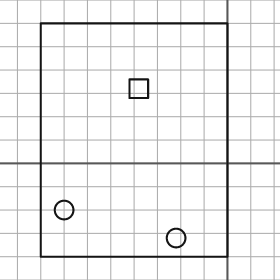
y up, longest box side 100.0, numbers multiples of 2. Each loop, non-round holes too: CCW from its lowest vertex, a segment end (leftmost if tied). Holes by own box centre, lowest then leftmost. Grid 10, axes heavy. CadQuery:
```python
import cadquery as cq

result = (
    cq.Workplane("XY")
    .moveTo(-80.0, -40.0)
    .lineTo(0.0, -40.0)
    .lineTo(0.0, 60.0)
    .lineTo(-80.0, 60.0)
    .close()
    .moveTo(-22.0, -32.0)
    .circle(4.0)
    .moveTo(-70.0, -20.0)
    .circle(4.0)
    .moveTo(-42.0, 28.0)
    .lineTo(-34.0, 28.0)
    .lineTo(-34.0, 36.0)
    .lineTo(-42.0, 36.0)
    .close()
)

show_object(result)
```